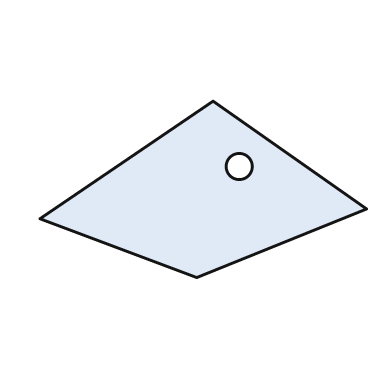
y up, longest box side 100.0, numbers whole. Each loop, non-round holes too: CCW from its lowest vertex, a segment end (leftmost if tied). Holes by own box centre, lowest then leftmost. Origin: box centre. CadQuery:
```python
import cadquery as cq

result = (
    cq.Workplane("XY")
    .moveTo(-2.0, -27.0)
    .lineTo(50.0, -6.0)
    .lineTo(3.0, 27.0)
    .lineTo(-50.0, -9.0)
    .close()
    .moveTo(11.0, 7.0)
    .circle(4.0)
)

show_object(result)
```